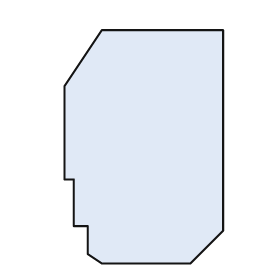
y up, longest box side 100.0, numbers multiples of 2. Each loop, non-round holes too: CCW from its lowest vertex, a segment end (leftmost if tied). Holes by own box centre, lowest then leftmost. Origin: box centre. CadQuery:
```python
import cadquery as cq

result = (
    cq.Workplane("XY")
    .moveTo(-18.0, -50.0)
    .lineTo(20.0, -50.0)
    .lineTo(34.0, -36.0)
    .lineTo(34.0, 50.0)
    .lineTo(-18.0, 50.0)
    .lineTo(-34.0, 26.0)
    .lineTo(-34.0, -14.0)
    .lineTo(-30.0, -14.0)
    .lineTo(-30.0, -34.0)
    .lineTo(-24.0, -34.0)
    .lineTo(-24.0, -46.0)
    .close()
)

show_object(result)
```